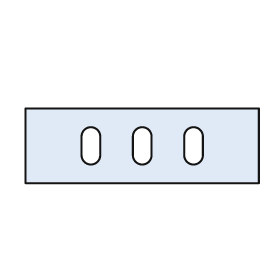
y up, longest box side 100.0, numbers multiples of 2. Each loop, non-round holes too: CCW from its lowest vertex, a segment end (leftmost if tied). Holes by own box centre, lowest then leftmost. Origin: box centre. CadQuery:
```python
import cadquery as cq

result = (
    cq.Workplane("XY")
    .moveTo(-50.0, -16.0)
    .lineTo(50.0, -16.0)
    .lineTo(50.0, 16.0)
    .lineTo(-50.0, 16.0)
    .close()
    .moveTo(-26.0, -4.0)
    .threePointArc((-22.0, -8.0), (-18.0, -4.0))
    .lineTo(-18.0, 4.0)
    .threePointArc((-22.0, 8.0), (-26.0, 4.0))
    .close()
    .moveTo(-4.0, -4.0)
    .threePointArc((0.0, -8.0), (4.0, -4.0))
    .lineTo(4.0, 4.0)
    .threePointArc((0.0, 8.0), (-4.0, 4.0))
    .close()
    .moveTo(18.0, -4.0)
    .threePointArc((22.0, -8.0), (26.0, -4.0))
    .lineTo(26.0, 4.0)
    .threePointArc((22.0, 8.0), (18.0, 4.0))
    .close()
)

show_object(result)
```